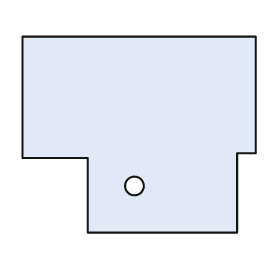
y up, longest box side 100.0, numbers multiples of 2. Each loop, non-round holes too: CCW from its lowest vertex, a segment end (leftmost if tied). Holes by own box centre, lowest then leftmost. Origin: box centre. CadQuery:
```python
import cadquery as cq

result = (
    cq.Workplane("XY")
    .moveTo(-22.0, -42.0)
    .lineTo(42.0, -42.0)
    .lineTo(42.0, -8.0)
    .lineTo(50.0, -8.0)
    .lineTo(50.0, 42.0)
    .lineTo(-50.0, 42.0)
    .lineTo(-50.0, -10.0)
    .lineTo(-22.0, -10.0)
    .close()
    .moveTo(-2.0, -22.0)
    .circle(4.0)
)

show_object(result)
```